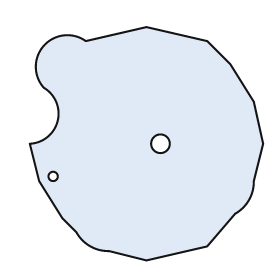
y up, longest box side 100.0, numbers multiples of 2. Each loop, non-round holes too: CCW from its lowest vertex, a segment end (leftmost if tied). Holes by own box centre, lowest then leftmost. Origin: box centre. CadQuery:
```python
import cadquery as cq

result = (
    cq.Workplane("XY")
    .moveTo(0.0, -50.0)
    .lineTo(26.0, -44.0)
    .lineTo(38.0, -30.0)
    .threePointArc((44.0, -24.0), (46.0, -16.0))
    .lineTo(50.0, 0.0)
    .lineTo(46.0, 18.0)
    .lineTo(36.0, 34.0)
    .lineTo(26.0, 44.0)
    .lineTo(0.0, 50.0)
    .lineTo(-26.0, 44.0)
    .threePointArc((-44.0, 42.0), (-44.0, 24.0))
    .threePointArc((-38.0, 10.0), (-50.0, 0.0))
    .lineTo(-46.0, -16.0)
    .lineTo(-36.0, -32.0)
    .lineTo(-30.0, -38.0)
    .threePointArc((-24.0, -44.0), (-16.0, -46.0))
    .close()
    .moveTo(-40.0, -14.0)
    .circle(2.0)
    .moveTo(6.0, 0.0)
    .circle(4.0)
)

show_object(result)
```